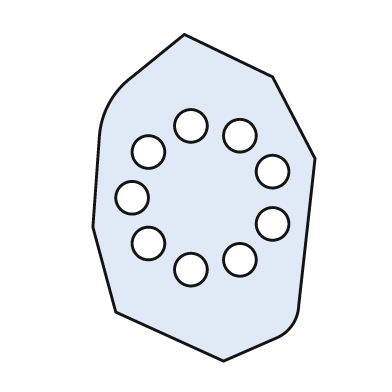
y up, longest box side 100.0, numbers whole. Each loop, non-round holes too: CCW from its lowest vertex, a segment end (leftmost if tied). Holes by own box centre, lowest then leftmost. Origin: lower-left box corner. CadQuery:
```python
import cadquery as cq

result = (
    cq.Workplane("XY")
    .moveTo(40.0, 0.0)
    .lineTo(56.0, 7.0)
    .threePointArc((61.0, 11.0), (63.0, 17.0))
    .lineTo(68.0, 62.0)
    .lineTo(55.0, 87.0)
    .lineTo(28.0, 100.0)
    .lineTo(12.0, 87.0)
    .threePointArc((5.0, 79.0), (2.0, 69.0))
    .lineTo(0.0, 41.0)
    .lineTo(7.0, 15.0)
    .close()
    .moveTo(30.0, 28.0)
    .circle(5.0)
    .moveTo(45.0, 31.0)
    .circle(5.0)
    .moveTo(17.0, 36.0)
    .circle(5.0)
    .moveTo(55.0, 42.0)
    .circle(5.0)
    .moveTo(12.0, 50.0)
    .circle(5.0)
    .moveTo(55.0, 58.0)
    .circle(5.0)
    .moveTo(17.0, 64.0)
    .circle(5.0)
    .moveTo(45.0, 69.0)
    .circle(5.0)
    .moveTo(30.0, 72.0)
    .circle(5.0)
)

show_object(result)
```